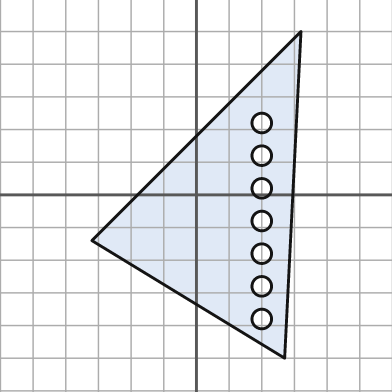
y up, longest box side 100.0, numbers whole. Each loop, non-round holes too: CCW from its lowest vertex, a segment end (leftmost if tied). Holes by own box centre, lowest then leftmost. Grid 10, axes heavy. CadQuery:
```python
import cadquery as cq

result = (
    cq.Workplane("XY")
    .moveTo(27.0, -50.0)
    .lineTo(32.0, 50.0)
    .lineTo(-32.0, -14.0)
    .close()
    .moveTo(20.0, -38.0)
    .circle(3.0)
    .moveTo(20.0, -28.0)
    .circle(3.0)
    .moveTo(20.0, -18.0)
    .circle(3.0)
    .moveTo(20.0, -8.0)
    .circle(3.0)
    .moveTo(20.0, 2.0)
    .circle(3.0)
    .moveTo(20.0, 12.0)
    .circle(3.0)
    .moveTo(20.0, 22.0)
    .circle(3.0)
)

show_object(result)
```